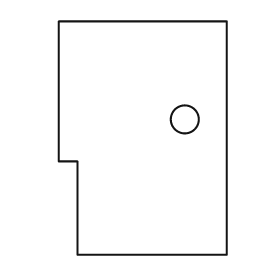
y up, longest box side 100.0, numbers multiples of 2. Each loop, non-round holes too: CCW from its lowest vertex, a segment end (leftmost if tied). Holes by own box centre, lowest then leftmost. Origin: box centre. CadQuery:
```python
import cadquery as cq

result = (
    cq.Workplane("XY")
    .moveTo(-28.0, -50.0)
    .lineTo(36.0, -50.0)
    .lineTo(36.0, 50.0)
    .lineTo(-36.0, 50.0)
    .lineTo(-36.0, -10.0)
    .lineTo(-28.0, -10.0)
    .close()
    .moveTo(18.0, 8.0)
    .circle(6.0)
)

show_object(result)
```